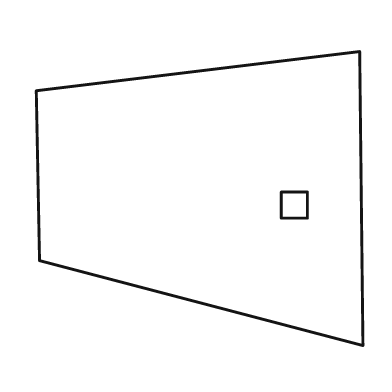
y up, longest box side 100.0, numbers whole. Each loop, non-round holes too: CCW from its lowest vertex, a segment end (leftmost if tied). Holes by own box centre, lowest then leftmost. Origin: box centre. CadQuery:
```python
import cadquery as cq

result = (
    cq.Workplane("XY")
    .moveTo(50.0, -45.0)
    .lineTo(49.0, 45.0)
    .lineTo(-50.0, 33.0)
    .lineTo(-49.0, -19.0)
    .close()
    .moveTo(25.0, -6.0)
    .lineTo(33.0, -6.0)
    .lineTo(33.0, 2.0)
    .lineTo(25.0, 2.0)
    .close()
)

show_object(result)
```